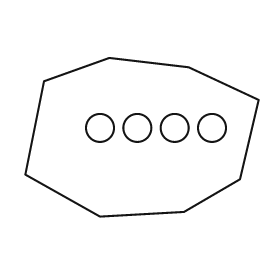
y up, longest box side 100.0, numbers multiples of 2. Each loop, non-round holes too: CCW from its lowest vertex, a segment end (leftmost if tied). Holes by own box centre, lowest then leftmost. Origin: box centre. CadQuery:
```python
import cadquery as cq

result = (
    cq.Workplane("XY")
    .moveTo(-18.0, -34.0)
    .lineTo(18.0, -32.0)
    .lineTo(42.0, -18.0)
    .lineTo(50.0, 16.0)
    .lineTo(20.0, 30.0)
    .lineTo(-14.0, 34.0)
    .lineTo(-42.0, 24.0)
    .lineTo(-50.0, -16.0)
    .close()
    .moveTo(-18.0, 4.0)
    .circle(6.0)
    .moveTo(-2.0, 4.0)
    .circle(6.0)
    .moveTo(14.0, 4.0)
    .circle(6.0)
    .moveTo(30.0, 4.0)
    .circle(6.0)
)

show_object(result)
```